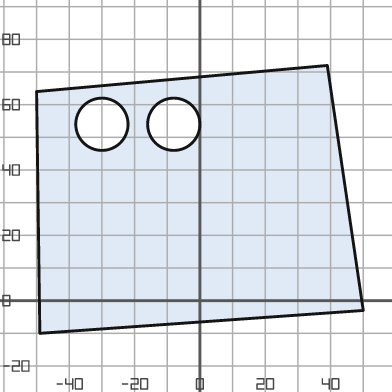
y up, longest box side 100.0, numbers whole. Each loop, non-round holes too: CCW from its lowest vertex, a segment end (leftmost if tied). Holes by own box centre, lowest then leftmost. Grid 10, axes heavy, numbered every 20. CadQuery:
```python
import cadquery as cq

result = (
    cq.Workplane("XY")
    .moveTo(-49.0, -10.0)
    .lineTo(50.0, -3.0)
    .lineTo(39.0, 72.0)
    .lineTo(-50.0, 64.0)
    .close()
    .moveTo(-30.0, 54.0)
    .circle(8.0)
    .moveTo(-8.0, 54.0)
    .circle(8.0)
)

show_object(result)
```